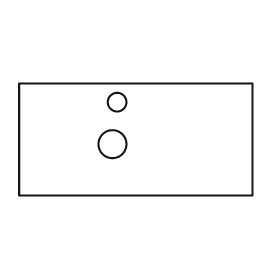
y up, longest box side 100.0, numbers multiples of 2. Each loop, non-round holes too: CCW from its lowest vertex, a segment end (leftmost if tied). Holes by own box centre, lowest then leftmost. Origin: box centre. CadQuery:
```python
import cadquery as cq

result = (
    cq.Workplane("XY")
    .moveTo(-50.0, -24.0)
    .lineTo(50.0, -24.0)
    .lineTo(50.0, 24.0)
    .lineTo(-50.0, 24.0)
    .close()
    .moveTo(-10.0, -2.0)
    .circle(6.0)
    .moveTo(-8.0, 16.0)
    .circle(4.0)
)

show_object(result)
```